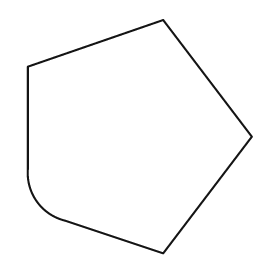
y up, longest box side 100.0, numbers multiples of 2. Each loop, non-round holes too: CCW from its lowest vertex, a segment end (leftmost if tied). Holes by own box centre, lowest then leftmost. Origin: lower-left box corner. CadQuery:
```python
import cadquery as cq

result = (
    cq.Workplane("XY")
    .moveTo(58.0, 0.0)
    .lineTo(96.0, 50.0)
    .lineTo(58.0, 100.0)
    .lineTo(0.0, 80.0)
    .lineTo(0.0, 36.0)
    .threePointArc((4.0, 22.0), (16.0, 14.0))
    .close()
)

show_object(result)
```